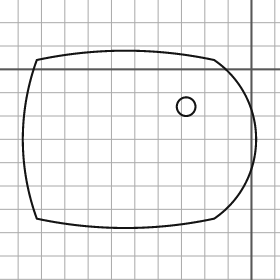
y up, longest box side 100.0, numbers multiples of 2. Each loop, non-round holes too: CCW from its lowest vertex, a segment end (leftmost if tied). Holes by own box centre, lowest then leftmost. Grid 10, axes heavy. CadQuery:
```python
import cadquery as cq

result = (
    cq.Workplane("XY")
    .moveTo(-92.0, -64.0)
    .threePointArc((-54.0, -68.0), (-16.0, -64.0))
    .threePointArc((2.0, -30.0), (-16.0, 4.0))
    .threePointArc((-54.0, 8.0), (-92.0, 4.0))
    .threePointArc((-98.0, -30.0), (-92.0, -64.0))
    .close()
    .moveTo(-28.0, -16.0)
    .circle(4.0)
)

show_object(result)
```